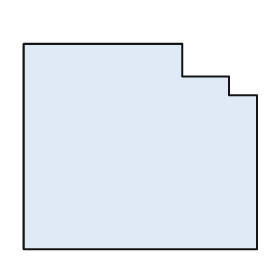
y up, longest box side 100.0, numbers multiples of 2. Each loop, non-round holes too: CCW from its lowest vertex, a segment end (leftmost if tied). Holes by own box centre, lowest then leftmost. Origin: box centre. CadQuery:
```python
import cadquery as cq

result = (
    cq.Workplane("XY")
    .moveTo(-50.0, -44.0)
    .lineTo(50.0, -44.0)
    .lineTo(50.0, 22.0)
    .lineTo(38.0, 22.0)
    .lineTo(38.0, 30.0)
    .lineTo(18.0, 30.0)
    .lineTo(18.0, 44.0)
    .lineTo(-50.0, 44.0)
    .close()
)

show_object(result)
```